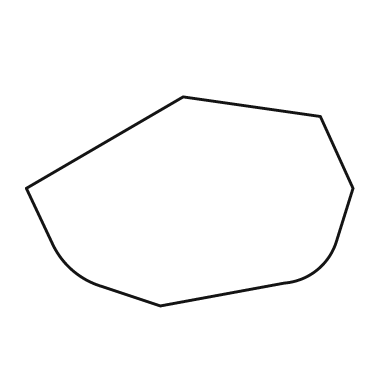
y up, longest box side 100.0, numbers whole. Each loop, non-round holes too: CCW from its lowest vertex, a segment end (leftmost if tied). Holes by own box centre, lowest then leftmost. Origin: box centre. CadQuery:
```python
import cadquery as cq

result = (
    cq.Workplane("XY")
    .moveTo(-9.0, -32.0)
    .lineTo(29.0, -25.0)
    .threePointArc((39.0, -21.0), (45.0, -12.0))
    .lineTo(50.0, 4.0)
    .lineTo(40.0, 26.0)
    .lineTo(-2.0, 32.0)
    .lineTo(-50.0, 4.0)
    .lineTo(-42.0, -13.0)
    .threePointArc((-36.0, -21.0), (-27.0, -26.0))
    .close()
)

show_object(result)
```